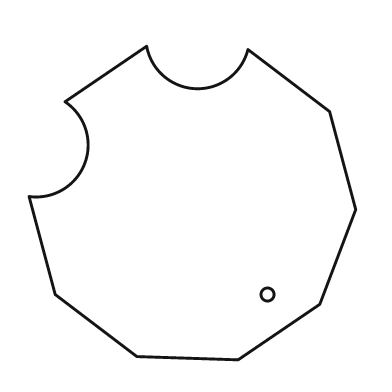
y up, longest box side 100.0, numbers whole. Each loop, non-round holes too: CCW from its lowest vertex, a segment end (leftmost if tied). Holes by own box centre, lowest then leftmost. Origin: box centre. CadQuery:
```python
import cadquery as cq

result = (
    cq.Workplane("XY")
    .moveTo(14.0, -48.0)
    .lineTo(39.0, -31.0)
    .lineTo(50.0, -2.0)
    .lineTo(42.0, 28.0)
    .lineTo(17.0, 47.0)
    .threePointArc((1.0, 35.0), (-14.0, 48.0))
    .lineTo(-39.0, 31.0)
    .threePointArc((-33.0, 12.0), (-50.0, 2.0))
    .lineTo(-42.0, -28.0)
    .lineTo(-17.0, -47.0)
    .close()
    .moveTo(23.0, -28.0)
    .circle(2.0)
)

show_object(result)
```